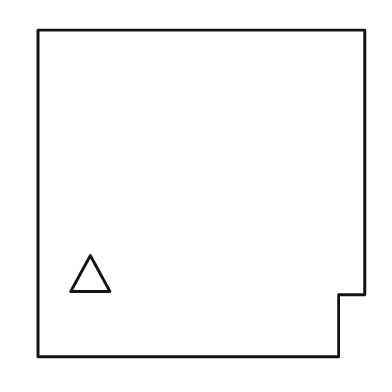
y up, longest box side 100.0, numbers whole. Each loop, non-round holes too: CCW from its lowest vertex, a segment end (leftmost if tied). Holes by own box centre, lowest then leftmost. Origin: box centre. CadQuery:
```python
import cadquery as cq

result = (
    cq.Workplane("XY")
    .moveTo(-50.0, -50.0)
    .lineTo(42.0, -50.0)
    .lineTo(42.0, -31.0)
    .lineTo(50.0, -31.0)
    .lineTo(50.0, 50.0)
    .lineTo(-50.0, 50.0)
    .close()
    .moveTo(-40.0, -30.0)
    .lineTo(-28.0, -30.0)
    .lineTo(-34.0, -19.0)
    .close()
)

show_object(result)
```